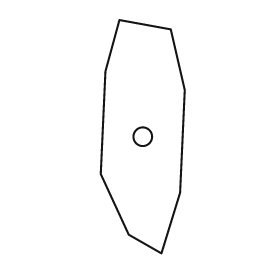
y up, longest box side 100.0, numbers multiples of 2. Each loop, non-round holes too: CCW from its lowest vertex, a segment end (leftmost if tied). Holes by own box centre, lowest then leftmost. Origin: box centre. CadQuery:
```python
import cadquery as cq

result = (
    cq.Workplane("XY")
    .moveTo(8.0, -50.0)
    .lineTo(16.0, -24.0)
    .lineTo(18.0, 20.0)
    .lineTo(12.0, 46.0)
    .lineTo(-10.0, 50.0)
    .lineTo(-16.0, 28.0)
    .lineTo(-18.0, -16.0)
    .lineTo(-6.0, -42.0)
    .close()
    .moveTo(0.0, 0.0)
    .circle(4.0)
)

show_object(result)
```